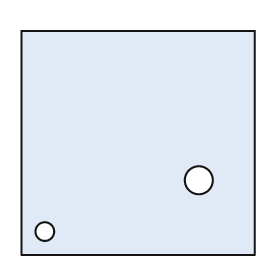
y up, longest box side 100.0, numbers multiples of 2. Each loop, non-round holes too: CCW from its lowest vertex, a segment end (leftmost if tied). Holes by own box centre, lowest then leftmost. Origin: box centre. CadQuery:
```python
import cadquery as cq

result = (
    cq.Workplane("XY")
    .moveTo(-50.0, -48.0)
    .lineTo(50.0, -48.0)
    .lineTo(50.0, 48.0)
    .lineTo(-50.0, 48.0)
    .close()
    .moveTo(-40.0, -38.0)
    .circle(4.0)
    .moveTo(26.0, -16.0)
    .circle(6.0)
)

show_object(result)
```